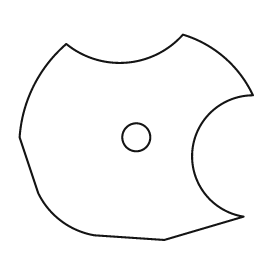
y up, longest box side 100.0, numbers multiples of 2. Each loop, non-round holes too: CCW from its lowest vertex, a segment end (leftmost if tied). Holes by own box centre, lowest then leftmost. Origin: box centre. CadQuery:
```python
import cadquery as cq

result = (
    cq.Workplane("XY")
    .moveTo(12.0, -44.0)
    .lineTo(46.0, -34.0)
    .threePointArc((24.0, -6.0), (50.0, 18.0))
    .threePointArc((38.0, 34.0), (20.0, 44.0))
    .threePointArc((-4.0, 32.0), (-30.0, 40.0))
    .threePointArc((-44.0, 22.0), (-50.0, 0.0))
    .lineTo(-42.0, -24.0)
    .threePointArc((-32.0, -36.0), (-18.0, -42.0))
    .close()
    .moveTo(0.0, 0.0)
    .circle(6.0)
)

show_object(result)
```